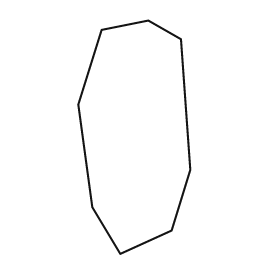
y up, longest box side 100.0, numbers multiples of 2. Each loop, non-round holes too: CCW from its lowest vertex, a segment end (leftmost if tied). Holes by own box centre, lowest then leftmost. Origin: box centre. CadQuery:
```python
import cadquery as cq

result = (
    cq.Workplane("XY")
    .moveTo(-6.0, -50.0)
    .lineTo(16.0, -40.0)
    .lineTo(24.0, -14.0)
    .lineTo(20.0, 42.0)
    .lineTo(6.0, 50.0)
    .lineTo(-14.0, 46.0)
    .lineTo(-24.0, 14.0)
    .lineTo(-18.0, -30.0)
    .close()
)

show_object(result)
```